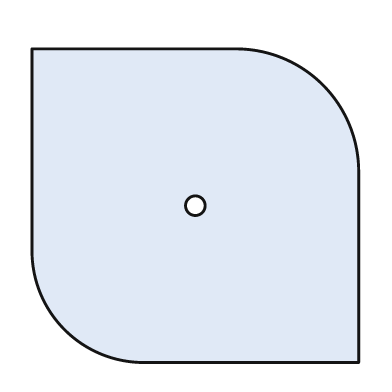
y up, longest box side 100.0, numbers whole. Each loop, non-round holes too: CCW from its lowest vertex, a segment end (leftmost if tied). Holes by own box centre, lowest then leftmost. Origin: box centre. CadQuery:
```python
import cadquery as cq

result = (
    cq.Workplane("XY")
    .moveTo(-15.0, -48.0)
    .lineTo(50.0, -48.0)
    .lineTo(50.0, 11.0)
    .threePointArc((39.0, 37.0), (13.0, 48.0))
    .lineTo(-50.0, 48.0)
    .lineTo(-50.0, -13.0)
    .threePointArc((-40.0, -38.0), (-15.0, -48.0))
    .close()
    .moveTo(0.0, 0.0)
    .circle(3.0)
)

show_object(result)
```